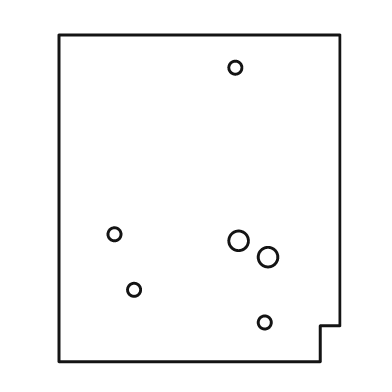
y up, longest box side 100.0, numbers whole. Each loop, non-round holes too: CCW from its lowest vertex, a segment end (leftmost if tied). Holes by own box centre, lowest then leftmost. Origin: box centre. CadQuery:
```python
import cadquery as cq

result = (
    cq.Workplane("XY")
    .moveTo(-43.0, -50.0)
    .lineTo(37.0, -50.0)
    .lineTo(37.0, -39.0)
    .lineTo(43.0, -39.0)
    .lineTo(43.0, 50.0)
    .lineTo(-43.0, 50.0)
    .close()
    .moveTo(20.0, -38.0)
    .circle(2.0)
    .moveTo(-20.0, -28.0)
    .circle(2.0)
    .moveTo(21.0, -18.0)
    .circle(3.0)
    .moveTo(12.0, -13.0)
    .circle(3.0)
    .moveTo(-26.0, -11.0)
    .circle(2.0)
    .moveTo(11.0, 40.0)
    .circle(2.0)
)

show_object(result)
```